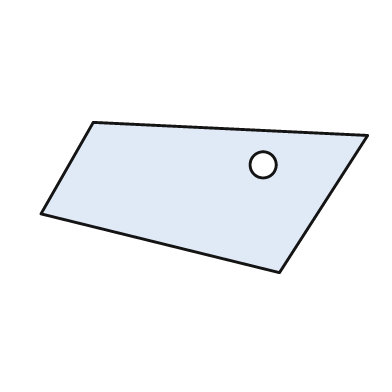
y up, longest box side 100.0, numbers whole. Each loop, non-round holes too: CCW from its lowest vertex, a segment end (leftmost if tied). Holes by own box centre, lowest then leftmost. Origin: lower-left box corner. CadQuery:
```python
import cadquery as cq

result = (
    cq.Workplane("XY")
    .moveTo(73.0, 0.0)
    .lineTo(100.0, 42.0)
    .lineTo(16.0, 46.0)
    .lineTo(0.0, 18.0)
    .close()
    .moveTo(68.0, 33.0)
    .circle(4.0)
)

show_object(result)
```